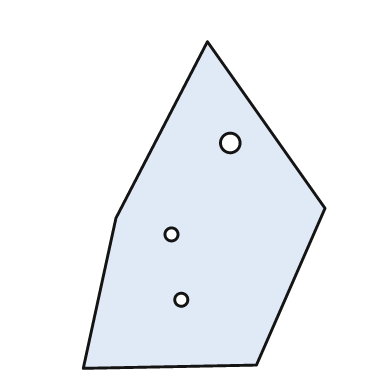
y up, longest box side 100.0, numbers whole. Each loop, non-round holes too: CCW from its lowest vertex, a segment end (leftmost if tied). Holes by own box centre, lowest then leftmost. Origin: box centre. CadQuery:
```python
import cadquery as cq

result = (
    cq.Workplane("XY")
    .moveTo(-37.0, -50.0)
    .lineTo(16.0, -49.0)
    .lineTo(37.0, -1.0)
    .lineTo(1.0, 50.0)
    .lineTo(-27.0, -4.0)
    .close()
    .moveTo(-7.0, -29.0)
    .circle(2.0)
    .moveTo(-10.0, -9.0)
    .circle(2.0)
    .moveTo(8.0, 19.0)
    .circle(3.0)
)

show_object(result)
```